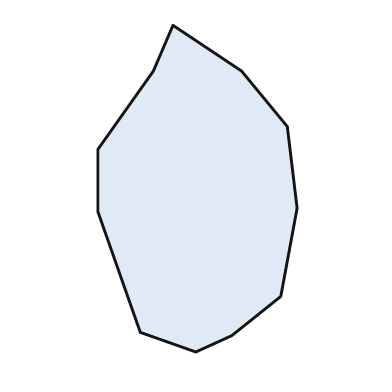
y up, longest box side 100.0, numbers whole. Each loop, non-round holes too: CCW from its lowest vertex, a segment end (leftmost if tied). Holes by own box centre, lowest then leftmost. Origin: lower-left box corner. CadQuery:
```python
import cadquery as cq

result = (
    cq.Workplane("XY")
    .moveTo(30.0, 0.0)
    .lineTo(41.0, 5.0)
    .lineTo(56.0, 17.0)
    .lineTo(61.0, 44.0)
    .lineTo(58.0, 69.0)
    .lineTo(44.0, 86.0)
    .lineTo(23.0, 100.0)
    .lineTo(17.0, 86.0)
    .lineTo(0.0, 62.0)
    .lineTo(0.0, 43.0)
    .lineTo(13.0, 6.0)
    .close()
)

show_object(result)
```